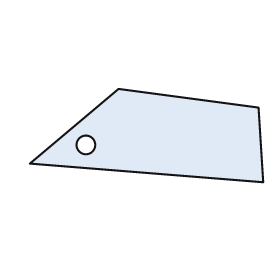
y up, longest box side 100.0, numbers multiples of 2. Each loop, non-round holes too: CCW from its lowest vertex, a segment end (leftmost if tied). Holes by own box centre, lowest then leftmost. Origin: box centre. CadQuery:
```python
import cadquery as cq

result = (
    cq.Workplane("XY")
    .moveTo(50.0, -20.0)
    .lineTo(48.0, 12.0)
    .lineTo(-12.0, 20.0)
    .lineTo(-50.0, -12.0)
    .close()
    .moveTo(-26.0, -4.0)
    .circle(4.0)
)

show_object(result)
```